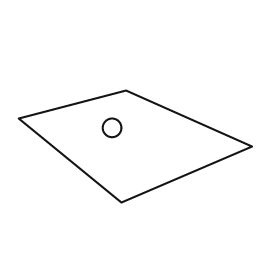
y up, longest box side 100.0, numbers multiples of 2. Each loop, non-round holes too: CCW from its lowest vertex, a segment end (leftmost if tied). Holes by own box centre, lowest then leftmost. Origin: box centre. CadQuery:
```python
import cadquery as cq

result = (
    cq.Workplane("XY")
    .moveTo(-6.0, -24.0)
    .lineTo(50.0, 0.0)
    .lineTo(-4.0, 24.0)
    .lineTo(-50.0, 12.0)
    .close()
    .moveTo(-10.0, 8.0)
    .circle(4.0)
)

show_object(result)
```